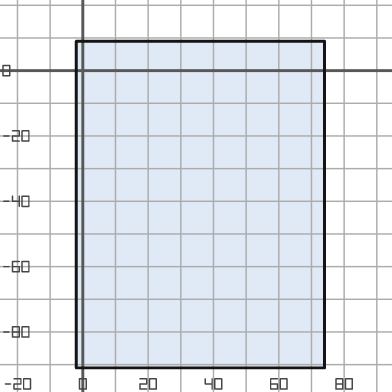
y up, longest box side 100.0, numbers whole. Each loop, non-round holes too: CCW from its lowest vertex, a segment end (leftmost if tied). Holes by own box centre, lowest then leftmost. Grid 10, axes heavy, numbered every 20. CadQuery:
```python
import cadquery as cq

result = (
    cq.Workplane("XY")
    .moveTo(-2.0, -91.0)
    .lineTo(74.0, -91.0)
    .lineTo(74.0, 9.0)
    .lineTo(-2.0, 9.0)
    .close()
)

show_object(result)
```